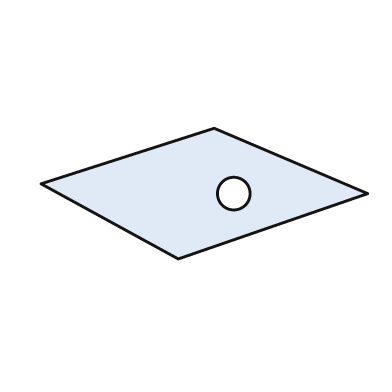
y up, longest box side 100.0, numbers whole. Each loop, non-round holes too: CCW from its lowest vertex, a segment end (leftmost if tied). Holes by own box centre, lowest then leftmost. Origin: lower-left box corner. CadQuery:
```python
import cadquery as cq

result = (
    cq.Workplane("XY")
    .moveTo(42.0, 0.0)
    .lineTo(100.0, 20.0)
    .lineTo(53.0, 40.0)
    .lineTo(0.0, 23.0)
    .close()
    .moveTo(59.0, 20.0)
    .circle(5.0)
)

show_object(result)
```